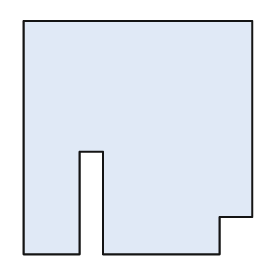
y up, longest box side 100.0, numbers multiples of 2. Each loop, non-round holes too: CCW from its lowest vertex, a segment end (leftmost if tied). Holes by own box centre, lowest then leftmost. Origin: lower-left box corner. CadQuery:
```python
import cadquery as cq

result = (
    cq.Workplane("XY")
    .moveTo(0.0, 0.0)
    .lineTo(24.0, 0.0)
    .lineTo(24.0, 44.0)
    .lineTo(34.0, 44.0)
    .lineTo(34.0, 0.0)
    .lineTo(84.0, 0.0)
    .lineTo(84.0, 16.0)
    .lineTo(98.0, 16.0)
    .lineTo(98.0, 100.0)
    .lineTo(0.0, 100.0)
    .close()
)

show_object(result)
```